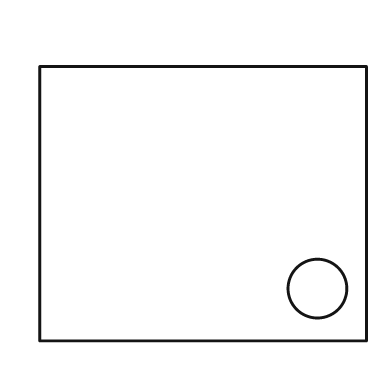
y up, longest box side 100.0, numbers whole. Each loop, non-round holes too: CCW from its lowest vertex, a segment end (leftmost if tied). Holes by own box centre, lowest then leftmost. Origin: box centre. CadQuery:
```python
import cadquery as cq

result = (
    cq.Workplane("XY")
    .moveTo(-50.0, -42.0)
    .lineTo(50.0, -42.0)
    .lineTo(50.0, 42.0)
    .lineTo(-50.0, 42.0)
    .close()
    .moveTo(35.0, -26.0)
    .circle(9.0)
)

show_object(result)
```